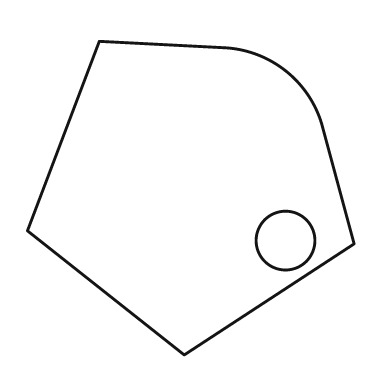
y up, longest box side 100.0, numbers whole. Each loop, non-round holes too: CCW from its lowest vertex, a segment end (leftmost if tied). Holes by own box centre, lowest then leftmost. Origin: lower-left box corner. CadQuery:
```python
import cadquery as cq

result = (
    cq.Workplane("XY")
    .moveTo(48.0, 0.0)
    .lineTo(100.0, 34.0)
    .lineTo(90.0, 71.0)
    .threePointArc((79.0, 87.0), (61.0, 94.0))
    .lineTo(22.0, 96.0)
    .lineTo(0.0, 38.0)
    .close()
    .moveTo(79.0, 35.0)
    .circle(9.0)
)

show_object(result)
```